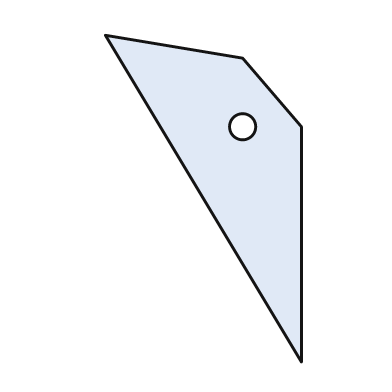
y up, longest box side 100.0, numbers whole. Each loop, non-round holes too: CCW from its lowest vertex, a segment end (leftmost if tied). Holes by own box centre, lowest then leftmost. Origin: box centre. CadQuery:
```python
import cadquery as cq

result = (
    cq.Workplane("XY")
    .moveTo(30.0, -50.0)
    .lineTo(30.0, 22.0)
    .lineTo(12.0, 43.0)
    .lineTo(-30.0, 50.0)
    .close()
    .moveTo(12.0, 22.0)
    .circle(4.0)
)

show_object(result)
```